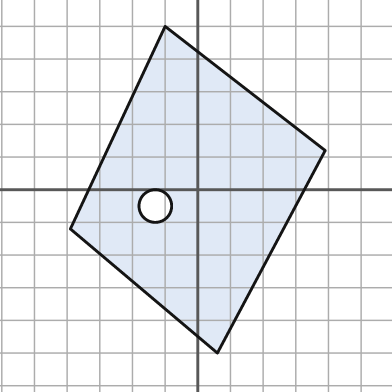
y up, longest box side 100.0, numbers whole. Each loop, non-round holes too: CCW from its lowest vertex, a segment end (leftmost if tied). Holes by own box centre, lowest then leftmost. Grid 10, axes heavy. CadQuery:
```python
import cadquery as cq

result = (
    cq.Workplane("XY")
    .moveTo(6.0, -50.0)
    .lineTo(39.0, 12.0)
    .lineTo(-10.0, 50.0)
    .lineTo(-39.0, -12.0)
    .close()
    .moveTo(-13.0, -5.0)
    .circle(5.0)
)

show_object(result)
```